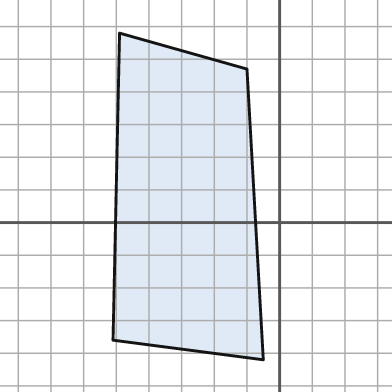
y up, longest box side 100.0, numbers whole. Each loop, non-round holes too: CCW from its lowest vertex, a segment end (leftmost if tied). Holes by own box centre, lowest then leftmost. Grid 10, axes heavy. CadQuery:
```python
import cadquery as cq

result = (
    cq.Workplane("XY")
    .moveTo(-5.0, -42.0)
    .lineTo(-10.0, 47.0)
    .lineTo(-49.0, 58.0)
    .lineTo(-51.0, -36.0)
    .close()
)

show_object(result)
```